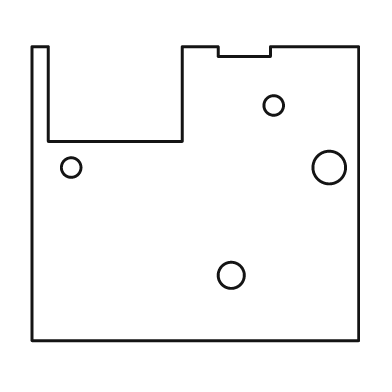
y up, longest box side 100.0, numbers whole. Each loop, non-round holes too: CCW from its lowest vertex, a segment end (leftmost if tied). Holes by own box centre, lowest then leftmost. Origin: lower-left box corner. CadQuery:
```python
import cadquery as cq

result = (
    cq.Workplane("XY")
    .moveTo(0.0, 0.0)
    .lineTo(100.0, 0.0)
    .lineTo(100.0, 90.0)
    .lineTo(73.0, 90.0)
    .lineTo(73.0, 87.0)
    .lineTo(57.0, 87.0)
    .lineTo(57.0, 90.0)
    .lineTo(46.0, 90.0)
    .lineTo(46.0, 61.0)
    .lineTo(5.0, 61.0)
    .lineTo(5.0, 90.0)
    .lineTo(0.0, 90.0)
    .close()
    .moveTo(61.0, 20.0)
    .circle(4.0)
    .moveTo(12.0, 53.0)
    .circle(3.0)
    .moveTo(91.0, 53.0)
    .circle(5.0)
    .moveTo(74.0, 72.0)
    .circle(3.0)
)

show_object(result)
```